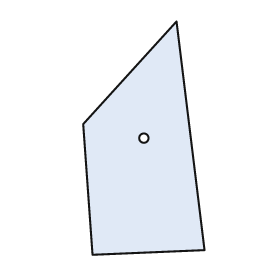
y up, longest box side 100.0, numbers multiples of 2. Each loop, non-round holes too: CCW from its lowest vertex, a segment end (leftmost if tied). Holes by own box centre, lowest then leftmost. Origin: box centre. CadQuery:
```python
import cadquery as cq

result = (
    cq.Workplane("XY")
    .moveTo(-22.0, -50.0)
    .lineTo(26.0, -48.0)
    .lineTo(14.0, 50.0)
    .lineTo(-26.0, 6.0)
    .close()
    .moveTo(0.0, 0.0)
    .circle(2.0)
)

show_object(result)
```